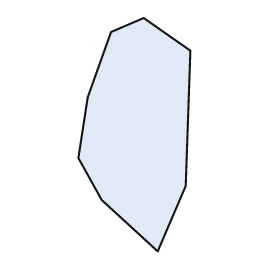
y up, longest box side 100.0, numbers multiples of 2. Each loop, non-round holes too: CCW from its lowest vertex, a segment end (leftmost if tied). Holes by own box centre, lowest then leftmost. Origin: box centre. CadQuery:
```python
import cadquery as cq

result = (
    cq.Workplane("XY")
    .moveTo(10.0, -50.0)
    .lineTo(22.0, -22.0)
    .lineTo(24.0, 36.0)
    .lineTo(4.0, 50.0)
    .lineTo(-10.0, 44.0)
    .lineTo(-20.0, 16.0)
    .lineTo(-24.0, -10.0)
    .lineTo(-14.0, -28.0)
    .close()
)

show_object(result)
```